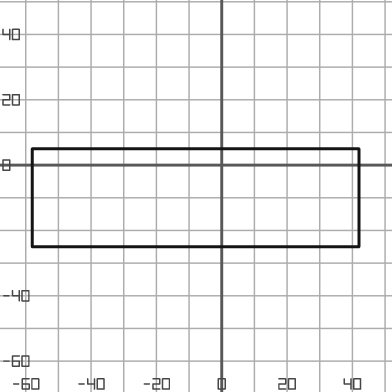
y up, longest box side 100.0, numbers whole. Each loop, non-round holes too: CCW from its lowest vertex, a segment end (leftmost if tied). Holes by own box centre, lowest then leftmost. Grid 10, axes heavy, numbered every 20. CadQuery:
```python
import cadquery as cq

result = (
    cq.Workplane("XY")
    .moveTo(-58.0, -25.0)
    .lineTo(42.0, -25.0)
    .lineTo(42.0, 5.0)
    .lineTo(-58.0, 5.0)
    .close()
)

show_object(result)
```